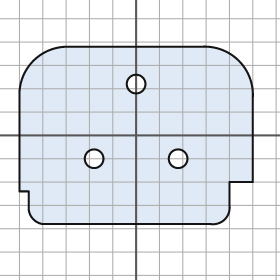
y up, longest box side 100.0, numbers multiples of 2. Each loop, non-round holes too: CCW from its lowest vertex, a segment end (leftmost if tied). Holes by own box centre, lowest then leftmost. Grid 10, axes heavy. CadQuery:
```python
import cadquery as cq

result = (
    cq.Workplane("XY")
    .moveTo(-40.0, -38.0)
    .lineTo(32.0, -38.0)
    .threePointArc((38.0, -36.0), (40.0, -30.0))
    .lineTo(40.0, -20.0)
    .lineTo(50.0, -20.0)
    .lineTo(50.0, 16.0)
    .threePointArc((44.0, 32.0), (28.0, 38.0))
    .lineTo(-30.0, 38.0)
    .threePointArc((-44.0, 32.0), (-50.0, 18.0))
    .lineTo(-50.0, -24.0)
    .lineTo(-46.0, -24.0)
    .lineTo(-46.0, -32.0)
    .threePointArc((-44.0, -36.0), (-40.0, -38.0))
    .close()
    .moveTo(-18.0, -10.0)
    .circle(4.0)
    .moveTo(18.0, -10.0)
    .circle(4.0)
    .moveTo(0.0, 22.0)
    .circle(4.0)
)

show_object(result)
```